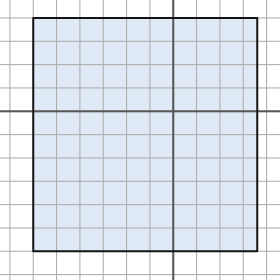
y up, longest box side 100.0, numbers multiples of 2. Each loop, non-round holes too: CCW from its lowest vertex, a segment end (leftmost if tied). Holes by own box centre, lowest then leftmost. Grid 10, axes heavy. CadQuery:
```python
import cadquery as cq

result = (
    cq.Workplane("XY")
    .moveTo(-60.0, -60.0)
    .lineTo(36.0, -60.0)
    .lineTo(36.0, 40.0)
    .lineTo(-60.0, 40.0)
    .close()
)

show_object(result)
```